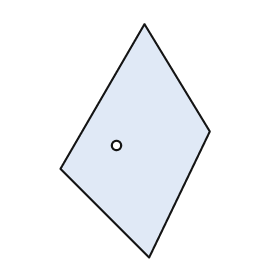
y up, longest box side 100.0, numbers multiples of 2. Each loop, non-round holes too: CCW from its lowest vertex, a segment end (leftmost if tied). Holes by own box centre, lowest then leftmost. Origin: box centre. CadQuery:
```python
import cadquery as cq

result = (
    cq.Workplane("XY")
    .moveTo(6.0, -50.0)
    .lineTo(32.0, 4.0)
    .lineTo(4.0, 50.0)
    .lineTo(-32.0, -12.0)
    .close()
    .moveTo(-8.0, -2.0)
    .circle(2.0)
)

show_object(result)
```